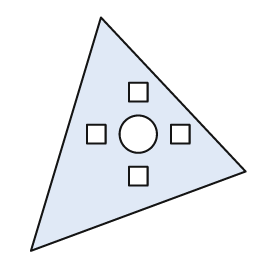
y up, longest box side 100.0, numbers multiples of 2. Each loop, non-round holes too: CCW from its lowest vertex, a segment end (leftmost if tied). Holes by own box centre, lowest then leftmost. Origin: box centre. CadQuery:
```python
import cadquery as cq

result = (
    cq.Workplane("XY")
    .moveTo(-46.0, -50.0)
    .lineTo(46.0, -16.0)
    .lineTo(-16.0, 50.0)
    .close()
    .moveTo(-4.0, -22.0)
    .lineTo(4.0, -22.0)
    .lineTo(4.0, -14.0)
    .lineTo(-4.0, -14.0)
    .close()
    .moveTo(-22.0, -4.0)
    .lineTo(-14.0, -4.0)
    .lineTo(-14.0, 4.0)
    .lineTo(-22.0, 4.0)
    .close()
    .moveTo(0.0, 0.0)
    .circle(8.0)
    .moveTo(14.0, -4.0)
    .lineTo(22.0, -4.0)
    .lineTo(22.0, 4.0)
    .lineTo(14.0, 4.0)
    .close()
    .moveTo(-4.0, 14.0)
    .lineTo(4.0, 14.0)
    .lineTo(4.0, 22.0)
    .lineTo(-4.0, 22.0)
    .close()
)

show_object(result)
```